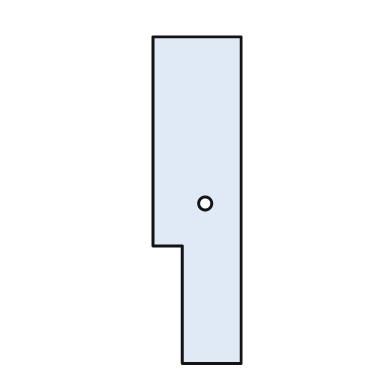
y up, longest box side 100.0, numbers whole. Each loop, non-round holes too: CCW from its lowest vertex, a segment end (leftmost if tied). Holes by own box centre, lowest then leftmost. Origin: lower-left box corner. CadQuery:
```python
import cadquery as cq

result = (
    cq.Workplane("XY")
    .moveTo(9.0, 0.0)
    .lineTo(27.0, 0.0)
    .lineTo(27.0, 100.0)
    .lineTo(0.0, 100.0)
    .lineTo(0.0, 36.0)
    .lineTo(9.0, 36.0)
    .close()
    .moveTo(16.0, 49.0)
    .circle(2.0)
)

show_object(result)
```